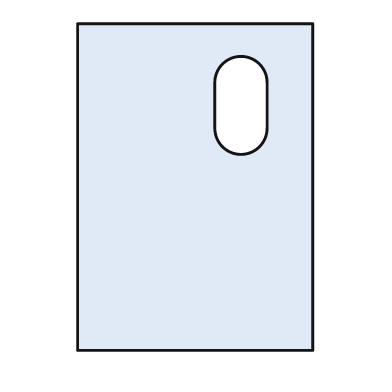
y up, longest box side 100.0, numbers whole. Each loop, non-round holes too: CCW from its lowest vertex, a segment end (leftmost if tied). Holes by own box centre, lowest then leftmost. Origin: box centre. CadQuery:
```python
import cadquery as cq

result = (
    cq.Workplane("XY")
    .moveTo(-36.0, -50.0)
    .lineTo(36.0, -50.0)
    .lineTo(36.0, 50.0)
    .lineTo(-36.0, 50.0)
    .close()
    .moveTo(6.0, 18.0)
    .threePointArc((14.0, 10.0), (22.0, 18.0))
    .lineTo(22.0, 32.0)
    .threePointArc((14.0, 40.0), (6.0, 32.0))
    .close()
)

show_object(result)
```